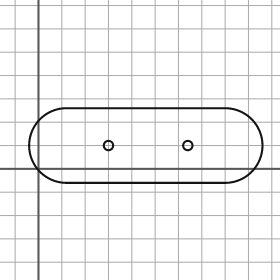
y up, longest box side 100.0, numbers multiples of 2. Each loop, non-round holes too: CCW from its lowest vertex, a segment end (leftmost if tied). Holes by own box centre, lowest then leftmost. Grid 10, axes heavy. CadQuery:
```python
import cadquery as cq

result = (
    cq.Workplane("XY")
    .moveTo(12.0, -6.0)
    .lineTo(80.0, -6.0)
    .threePointArc((96.0, 10.0), (80.0, 26.0))
    .lineTo(12.0, 26.0)
    .threePointArc((-4.0, 10.0), (12.0, -6.0))
    .close()
    .moveTo(30.0, 10.0)
    .circle(2.0)
    .moveTo(64.0, 10.0)
    .circle(2.0)
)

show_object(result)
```